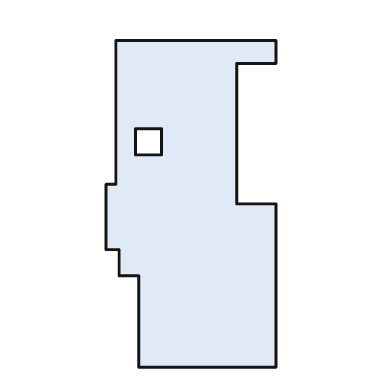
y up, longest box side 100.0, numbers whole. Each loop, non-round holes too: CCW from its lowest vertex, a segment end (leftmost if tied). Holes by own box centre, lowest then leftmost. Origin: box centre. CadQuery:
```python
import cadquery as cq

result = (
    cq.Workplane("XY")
    .moveTo(-16.0, -50.0)
    .lineTo(26.0, -50.0)
    .lineTo(26.0, 0.0)
    .lineTo(14.0, 0.0)
    .lineTo(14.0, 43.0)
    .lineTo(26.0, 43.0)
    .lineTo(26.0, 50.0)
    .lineTo(-23.0, 50.0)
    .lineTo(-23.0, 6.0)
    .lineTo(-26.0, 6.0)
    .lineTo(-26.0, -14.0)
    .lineTo(-22.0, -14.0)
    .lineTo(-22.0, -22.0)
    .lineTo(-16.0, -22.0)
    .close()
    .moveTo(-17.0, 15.0)
    .lineTo(-9.0, 15.0)
    .lineTo(-9.0, 23.0)
    .lineTo(-17.0, 23.0)
    .close()
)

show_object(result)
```